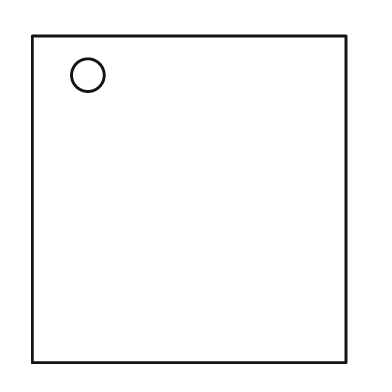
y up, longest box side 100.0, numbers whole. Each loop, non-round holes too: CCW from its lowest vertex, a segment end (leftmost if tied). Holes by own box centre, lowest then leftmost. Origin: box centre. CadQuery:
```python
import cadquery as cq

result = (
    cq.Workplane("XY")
    .moveTo(-48.0, -50.0)
    .lineTo(48.0, -50.0)
    .lineTo(48.0, 50.0)
    .lineTo(-48.0, 50.0)
    .close()
    .moveTo(-31.0, 38.0)
    .circle(5.0)
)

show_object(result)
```